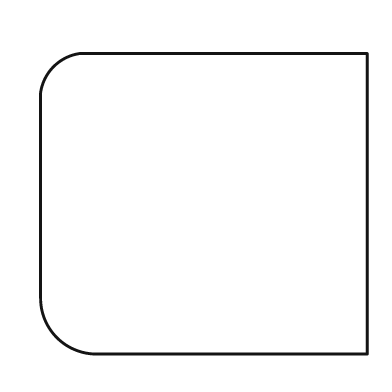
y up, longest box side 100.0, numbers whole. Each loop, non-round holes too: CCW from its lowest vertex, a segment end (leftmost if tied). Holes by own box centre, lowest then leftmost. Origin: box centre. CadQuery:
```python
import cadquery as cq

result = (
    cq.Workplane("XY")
    .moveTo(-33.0, -46.0)
    .lineTo(50.0, -46.0)
    .lineTo(50.0, 46.0)
    .lineTo(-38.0, 46.0)
    .threePointArc((-46.0, 42.0), (-50.0, 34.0))
    .lineTo(-50.0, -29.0)
    .threePointArc((-45.0, -41.0), (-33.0, -46.0))
    .close()
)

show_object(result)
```